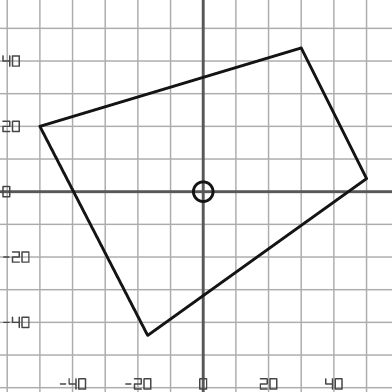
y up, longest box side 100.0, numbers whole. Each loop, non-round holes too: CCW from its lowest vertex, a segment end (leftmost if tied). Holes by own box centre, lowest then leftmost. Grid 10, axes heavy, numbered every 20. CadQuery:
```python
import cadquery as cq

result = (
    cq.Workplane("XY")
    .moveTo(-17.0, -44.0)
    .lineTo(50.0, 4.0)
    .lineTo(30.0, 44.0)
    .lineTo(-50.0, 20.0)
    .close()
    .moveTo(0.0, 0.0)
    .circle(3.0)
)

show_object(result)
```